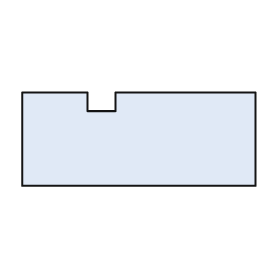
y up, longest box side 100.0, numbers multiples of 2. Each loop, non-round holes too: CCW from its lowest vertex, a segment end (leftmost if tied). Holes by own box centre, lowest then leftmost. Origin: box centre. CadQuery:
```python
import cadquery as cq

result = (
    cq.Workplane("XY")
    .moveTo(-50.0, -20.0)
    .lineTo(50.0, -20.0)
    .lineTo(50.0, 20.0)
    .lineTo(-10.0, 20.0)
    .lineTo(-10.0, 12.0)
    .lineTo(-22.0, 12.0)
    .lineTo(-22.0, 20.0)
    .lineTo(-50.0, 20.0)
    .close()
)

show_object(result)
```